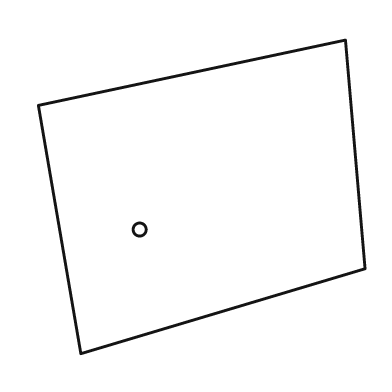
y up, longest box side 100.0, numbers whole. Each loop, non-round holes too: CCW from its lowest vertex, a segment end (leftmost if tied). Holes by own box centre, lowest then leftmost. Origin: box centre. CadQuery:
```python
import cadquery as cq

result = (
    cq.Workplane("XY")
    .moveTo(-37.0, -48.0)
    .lineTo(50.0, -22.0)
    .lineTo(44.0, 48.0)
    .lineTo(-50.0, 28.0)
    .close()
    .moveTo(-19.0, -10.0)
    .circle(2.0)
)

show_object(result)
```